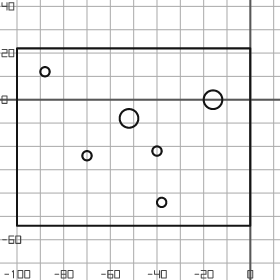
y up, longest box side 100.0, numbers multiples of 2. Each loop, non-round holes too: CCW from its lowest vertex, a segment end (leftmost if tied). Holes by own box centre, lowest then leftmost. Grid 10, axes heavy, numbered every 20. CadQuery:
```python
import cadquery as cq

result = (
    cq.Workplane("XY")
    .moveTo(-100.0, -54.0)
    .lineTo(0.0, -54.0)
    .lineTo(0.0, 22.0)
    .lineTo(-100.0, 22.0)
    .close()
    .moveTo(-38.0, -44.0)
    .circle(2.0)
    .moveTo(-70.0, -24.0)
    .circle(2.0)
    .moveTo(-40.0, -22.0)
    .circle(2.0)
    .moveTo(-52.0, -8.0)
    .circle(4.0)
    .moveTo(-16.0, 0.0)
    .circle(4.0)
    .moveTo(-88.0, 12.0)
    .circle(2.0)
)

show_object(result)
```